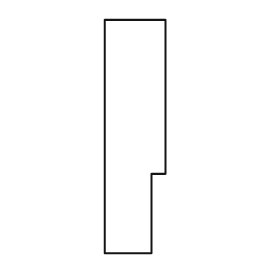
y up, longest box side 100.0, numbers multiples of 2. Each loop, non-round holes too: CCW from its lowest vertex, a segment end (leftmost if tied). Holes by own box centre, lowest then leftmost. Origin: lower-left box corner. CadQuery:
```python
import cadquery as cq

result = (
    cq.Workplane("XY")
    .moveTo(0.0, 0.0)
    .lineTo(20.0, 0.0)
    .lineTo(20.0, 34.0)
    .lineTo(26.0, 34.0)
    .lineTo(26.0, 100.0)
    .lineTo(0.0, 100.0)
    .close()
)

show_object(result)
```